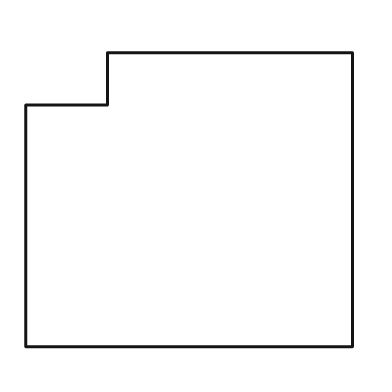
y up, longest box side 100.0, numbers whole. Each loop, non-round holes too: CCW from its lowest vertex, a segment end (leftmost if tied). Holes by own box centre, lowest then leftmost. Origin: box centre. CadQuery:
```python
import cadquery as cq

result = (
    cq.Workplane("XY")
    .moveTo(-50.0, -45.0)
    .lineTo(50.0, -45.0)
    .lineTo(50.0, 45.0)
    .lineTo(-25.0, 45.0)
    .lineTo(-25.0, 29.0)
    .lineTo(-50.0, 29.0)
    .close()
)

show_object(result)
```